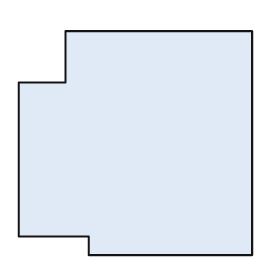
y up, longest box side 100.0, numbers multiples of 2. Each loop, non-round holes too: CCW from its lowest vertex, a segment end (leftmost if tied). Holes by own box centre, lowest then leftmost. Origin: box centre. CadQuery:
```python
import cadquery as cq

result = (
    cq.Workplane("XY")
    .moveTo(-20.0, -48.0)
    .lineTo(50.0, -48.0)
    .lineTo(50.0, 48.0)
    .lineTo(-30.0, 48.0)
    .lineTo(-30.0, 26.0)
    .lineTo(-50.0, 26.0)
    .lineTo(-50.0, -40.0)
    .lineTo(-20.0, -40.0)
    .close()
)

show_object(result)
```